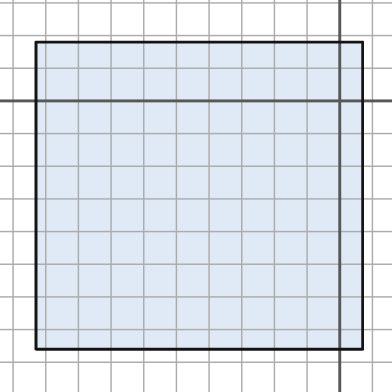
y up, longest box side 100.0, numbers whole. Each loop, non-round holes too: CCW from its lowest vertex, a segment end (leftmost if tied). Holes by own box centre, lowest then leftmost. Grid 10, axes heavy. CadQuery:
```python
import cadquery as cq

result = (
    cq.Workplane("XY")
    .moveTo(-93.0, -76.0)
    .lineTo(7.0, -76.0)
    .lineTo(7.0, 18.0)
    .lineTo(-93.0, 18.0)
    .close()
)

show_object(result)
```